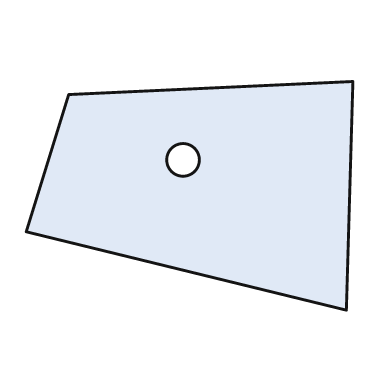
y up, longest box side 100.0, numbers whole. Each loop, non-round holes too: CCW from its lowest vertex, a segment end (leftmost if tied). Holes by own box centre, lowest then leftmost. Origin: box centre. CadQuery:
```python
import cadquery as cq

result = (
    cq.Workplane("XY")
    .moveTo(48.0, -35.0)
    .lineTo(50.0, 35.0)
    .lineTo(-37.0, 31.0)
    .lineTo(-50.0, -11.0)
    .close()
    .moveTo(-2.0, 11.0)
    .circle(5.0)
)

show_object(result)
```